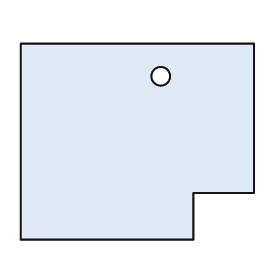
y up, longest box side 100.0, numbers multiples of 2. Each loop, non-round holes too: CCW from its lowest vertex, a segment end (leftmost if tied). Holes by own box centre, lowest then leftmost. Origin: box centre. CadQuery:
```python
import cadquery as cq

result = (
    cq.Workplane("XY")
    .moveTo(-50.0, -42.0)
    .lineTo(24.0, -42.0)
    .lineTo(24.0, -22.0)
    .lineTo(50.0, -22.0)
    .lineTo(50.0, 42.0)
    .lineTo(-50.0, 42.0)
    .close()
    .moveTo(10.0, 28.0)
    .circle(4.0)
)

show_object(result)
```